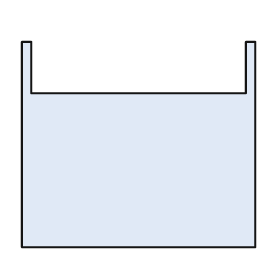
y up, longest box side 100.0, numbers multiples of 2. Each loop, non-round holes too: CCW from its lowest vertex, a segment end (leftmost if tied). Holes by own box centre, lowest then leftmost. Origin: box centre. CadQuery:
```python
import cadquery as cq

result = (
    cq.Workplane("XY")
    .moveTo(-50.0, -44.0)
    .lineTo(50.0, -44.0)
    .lineTo(50.0, 44.0)
    .lineTo(46.0, 44.0)
    .lineTo(46.0, 22.0)
    .lineTo(-46.0, 22.0)
    .lineTo(-46.0, 44.0)
    .lineTo(-50.0, 44.0)
    .close()
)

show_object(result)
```